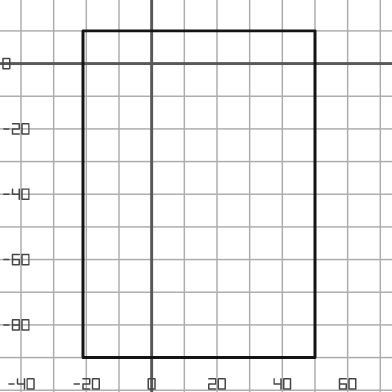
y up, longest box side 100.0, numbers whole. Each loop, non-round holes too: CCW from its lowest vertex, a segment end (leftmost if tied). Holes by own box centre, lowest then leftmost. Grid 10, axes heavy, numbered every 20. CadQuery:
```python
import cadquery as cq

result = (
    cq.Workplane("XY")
    .moveTo(-21.0, -90.0)
    .lineTo(50.0, -90.0)
    .lineTo(50.0, 10.0)
    .lineTo(-21.0, 10.0)
    .close()
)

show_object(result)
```